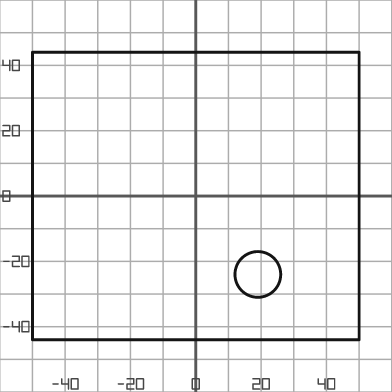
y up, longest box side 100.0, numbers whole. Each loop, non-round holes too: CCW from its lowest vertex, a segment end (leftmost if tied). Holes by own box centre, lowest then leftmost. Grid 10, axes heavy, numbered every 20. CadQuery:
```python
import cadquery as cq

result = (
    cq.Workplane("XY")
    .moveTo(-50.0, -44.0)
    .lineTo(50.0, -44.0)
    .lineTo(50.0, 44.0)
    .lineTo(-50.0, 44.0)
    .close()
    .moveTo(19.0, -24.0)
    .circle(7.0)
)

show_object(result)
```